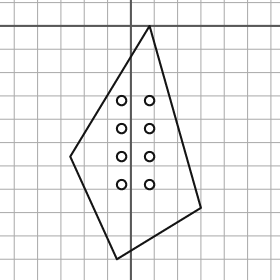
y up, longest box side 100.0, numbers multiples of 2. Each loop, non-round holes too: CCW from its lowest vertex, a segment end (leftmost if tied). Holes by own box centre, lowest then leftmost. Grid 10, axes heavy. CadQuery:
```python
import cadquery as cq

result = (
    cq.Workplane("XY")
    .moveTo(-6.0, -100.0)
    .lineTo(30.0, -78.0)
    .lineTo(8.0, 0.0)
    .lineTo(-26.0, -56.0)
    .close()
    .moveTo(-4.0, -68.0)
    .circle(2.0)
    .moveTo(8.0, -68.0)
    .circle(2.0)
    .moveTo(-4.0, -56.0)
    .circle(2.0)
    .moveTo(8.0, -56.0)
    .circle(2.0)
    .moveTo(-4.0, -44.0)
    .circle(2.0)
    .moveTo(8.0, -44.0)
    .circle(2.0)
    .moveTo(-4.0, -32.0)
    .circle(2.0)
    .moveTo(8.0, -32.0)
    .circle(2.0)
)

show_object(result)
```